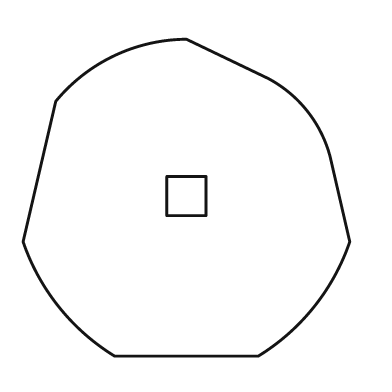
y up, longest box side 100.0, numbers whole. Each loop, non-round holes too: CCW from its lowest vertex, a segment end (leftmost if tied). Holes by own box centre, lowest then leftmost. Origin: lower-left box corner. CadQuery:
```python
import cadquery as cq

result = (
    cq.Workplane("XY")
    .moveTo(28.0, 0.0)
    .lineTo(72.0, 0.0)
    .threePointArc((89.0, 15.0), (100.0, 35.0))
    .lineTo(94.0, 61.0)
    .threePointArc((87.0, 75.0), (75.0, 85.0))
    .lineTo(50.0, 97.0)
    .threePointArc((28.0, 92.0), (10.0, 78.0))
    .lineTo(0.0, 35.0)
    .threePointArc((11.0, 15.0), (28.0, 0.0))
    .close()
    .moveTo(44.0, 43.0)
    .lineTo(56.0, 43.0)
    .lineTo(56.0, 55.0)
    .lineTo(44.0, 55.0)
    .close()
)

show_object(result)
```